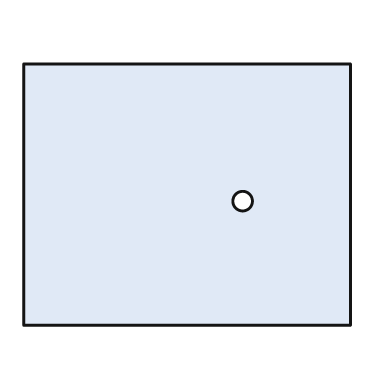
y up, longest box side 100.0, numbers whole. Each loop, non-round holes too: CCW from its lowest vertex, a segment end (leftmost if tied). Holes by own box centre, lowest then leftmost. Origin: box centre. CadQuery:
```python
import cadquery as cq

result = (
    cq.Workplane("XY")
    .moveTo(-50.0, -40.0)
    .lineTo(50.0, -40.0)
    .lineTo(50.0, 40.0)
    .lineTo(-50.0, 40.0)
    .close()
    .moveTo(17.0, -2.0)
    .circle(3.0)
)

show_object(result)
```